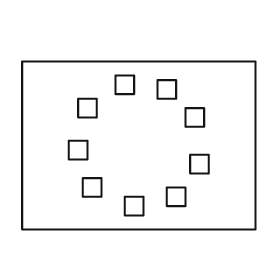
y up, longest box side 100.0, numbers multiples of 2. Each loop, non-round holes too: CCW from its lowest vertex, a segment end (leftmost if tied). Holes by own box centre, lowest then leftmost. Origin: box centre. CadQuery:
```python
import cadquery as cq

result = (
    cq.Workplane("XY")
    .moveTo(-50.0, -36.0)
    .lineTo(50.0, -36.0)
    .lineTo(50.0, 36.0)
    .lineTo(-50.0, 36.0)
    .close()
    .moveTo(-6.0, -30.0)
    .lineTo(2.0, -30.0)
    .lineTo(2.0, -22.0)
    .lineTo(-6.0, -22.0)
    .close()
    .moveTo(12.0, -26.0)
    .lineTo(20.0, -26.0)
    .lineTo(20.0, -18.0)
    .lineTo(12.0, -18.0)
    .close()
    .moveTo(-24.0, -22.0)
    .lineTo(-16.0, -22.0)
    .lineTo(-16.0, -14.0)
    .lineTo(-24.0, -14.0)
    .close()
    .moveTo(22.0, -12.0)
    .lineTo(30.0, -12.0)
    .lineTo(30.0, -4.0)
    .lineTo(22.0, -4.0)
    .close()
    .moveTo(-30.0, -6.0)
    .lineTo(-22.0, -6.0)
    .lineTo(-22.0, 2.0)
    .lineTo(-30.0, 2.0)
    .close()
    .moveTo(20.0, 8.0)
    .lineTo(28.0, 8.0)
    .lineTo(28.0, 16.0)
    .lineTo(20.0, 16.0)
    .close()
    .moveTo(-26.0, 12.0)
    .lineTo(-18.0, 12.0)
    .lineTo(-18.0, 20.0)
    .lineTo(-26.0, 20.0)
    .close()
    .moveTo(8.0, 20.0)
    .lineTo(16.0, 20.0)
    .lineTo(16.0, 28.0)
    .lineTo(8.0, 28.0)
    .close()
    .moveTo(-10.0, 22.0)
    .lineTo(-2.0, 22.0)
    .lineTo(-2.0, 30.0)
    .lineTo(-10.0, 30.0)
    .close()
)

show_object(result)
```